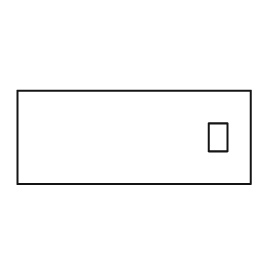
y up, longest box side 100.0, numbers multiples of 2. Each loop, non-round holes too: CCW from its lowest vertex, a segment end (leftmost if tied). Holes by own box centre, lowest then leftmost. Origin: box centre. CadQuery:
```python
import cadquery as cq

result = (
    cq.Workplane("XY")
    .moveTo(-50.0, -20.0)
    .lineTo(50.0, -20.0)
    .lineTo(50.0, 20.0)
    .lineTo(-50.0, 20.0)
    .close()
    .moveTo(32.0, -6.0)
    .lineTo(40.0, -6.0)
    .lineTo(40.0, 6.0)
    .lineTo(32.0, 6.0)
    .close()
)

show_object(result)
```